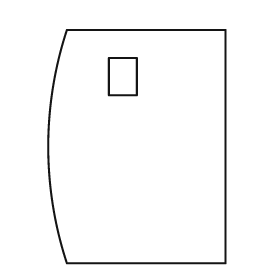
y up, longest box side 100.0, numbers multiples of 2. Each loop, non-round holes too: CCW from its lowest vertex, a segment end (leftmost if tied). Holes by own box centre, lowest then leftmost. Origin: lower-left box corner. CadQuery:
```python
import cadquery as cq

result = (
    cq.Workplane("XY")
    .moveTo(8.0, 0.0)
    .lineTo(76.0, 0.0)
    .lineTo(76.0, 100.0)
    .lineTo(8.0, 100.0)
    .threePointArc((0.0, 50.0), (8.0, 0.0))
    .close()
    .moveTo(26.0, 72.0)
    .lineTo(38.0, 72.0)
    .lineTo(38.0, 88.0)
    .lineTo(26.0, 88.0)
    .close()
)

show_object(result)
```